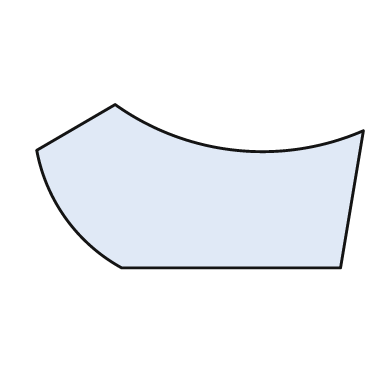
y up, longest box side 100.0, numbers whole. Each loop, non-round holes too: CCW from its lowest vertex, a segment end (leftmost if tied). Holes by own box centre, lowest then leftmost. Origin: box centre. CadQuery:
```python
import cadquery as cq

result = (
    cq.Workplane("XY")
    .moveTo(-24.0, -25.0)
    .lineTo(43.0, -25.0)
    .lineTo(50.0, 17.0)
    .threePointArc((11.0, 11.0), (-26.0, 25.0))
    .lineTo(-50.0, 11.0)
    .threePointArc((-41.0, -10.0), (-24.0, -25.0))
    .close()
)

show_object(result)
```